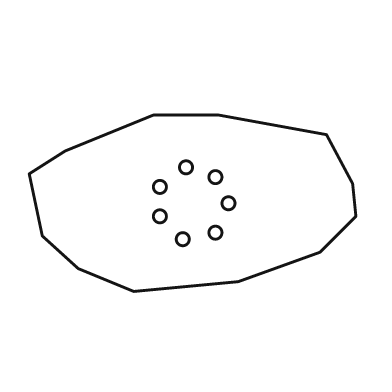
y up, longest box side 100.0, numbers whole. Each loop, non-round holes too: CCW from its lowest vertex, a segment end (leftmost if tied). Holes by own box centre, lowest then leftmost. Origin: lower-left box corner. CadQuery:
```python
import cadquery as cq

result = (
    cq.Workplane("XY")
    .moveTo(32.0, 0.0)
    .lineTo(64.0, 3.0)
    .lineTo(89.0, 12.0)
    .lineTo(100.0, 23.0)
    .lineTo(99.0, 33.0)
    .lineTo(91.0, 48.0)
    .lineTo(58.0, 54.0)
    .lineTo(38.0, 54.0)
    .lineTo(11.0, 43.0)
    .lineTo(0.0, 36.0)
    .lineTo(4.0, 17.0)
    .lineTo(15.0, 7.0)
    .close()
    .moveTo(47.0, 16.0)
    .circle(2.0)
    .moveTo(57.0, 18.0)
    .circle(2.0)
    .moveTo(40.0, 23.0)
    .circle(2.0)
    .moveTo(61.0, 27.0)
    .circle(2.0)
    .moveTo(40.0, 32.0)
    .circle(2.0)
    .moveTo(57.0, 35.0)
    .circle(2.0)
    .moveTo(48.0, 38.0)
    .circle(2.0)
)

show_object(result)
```